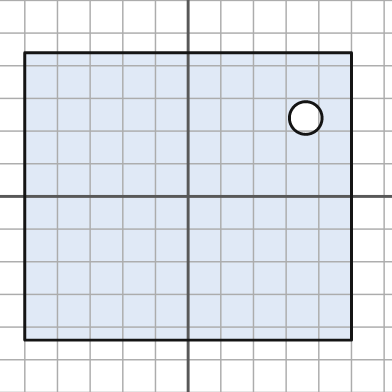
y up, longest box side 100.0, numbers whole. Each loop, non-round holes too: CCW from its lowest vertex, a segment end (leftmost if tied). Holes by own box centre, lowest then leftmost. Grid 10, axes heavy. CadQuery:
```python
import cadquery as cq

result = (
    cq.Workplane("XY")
    .moveTo(-50.0, -44.0)
    .lineTo(50.0, -44.0)
    .lineTo(50.0, 44.0)
    .lineTo(-50.0, 44.0)
    .close()
    .moveTo(36.0, 24.0)
    .circle(5.0)
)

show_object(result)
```